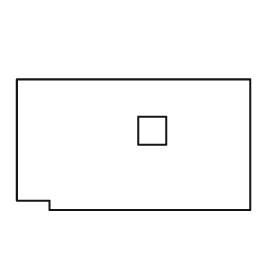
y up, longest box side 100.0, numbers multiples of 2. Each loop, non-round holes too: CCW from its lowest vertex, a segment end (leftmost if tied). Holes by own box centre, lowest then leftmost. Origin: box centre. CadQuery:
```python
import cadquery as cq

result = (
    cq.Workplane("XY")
    .moveTo(-36.0, -28.0)
    .lineTo(50.0, -28.0)
    .lineTo(50.0, 28.0)
    .lineTo(-50.0, 28.0)
    .lineTo(-50.0, -24.0)
    .lineTo(-36.0, -24.0)
    .close()
    .moveTo(2.0, 0.0)
    .lineTo(14.0, 0.0)
    .lineTo(14.0, 12.0)
    .lineTo(2.0, 12.0)
    .close()
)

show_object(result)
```